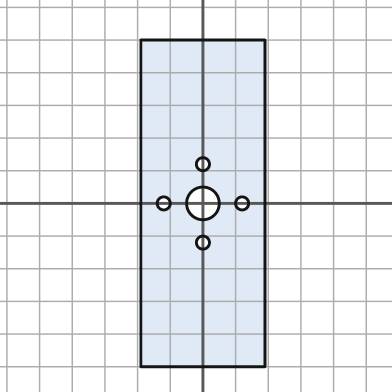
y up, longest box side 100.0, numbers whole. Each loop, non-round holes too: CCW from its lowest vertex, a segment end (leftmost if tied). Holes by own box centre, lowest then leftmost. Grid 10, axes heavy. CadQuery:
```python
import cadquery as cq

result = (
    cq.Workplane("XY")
    .moveTo(-19.0, -50.0)
    .lineTo(19.0, -50.0)
    .lineTo(19.0, 50.0)
    .lineTo(-19.0, 50.0)
    .close()
    .moveTo(0.0, -12.0)
    .circle(2.0)
    .moveTo(-12.0, 0.0)
    .circle(2.0)
    .moveTo(0.0, 0.0)
    .circle(5.0)
    .moveTo(12.0, 0.0)
    .circle(2.0)
    .moveTo(0.0, 12.0)
    .circle(2.0)
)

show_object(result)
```